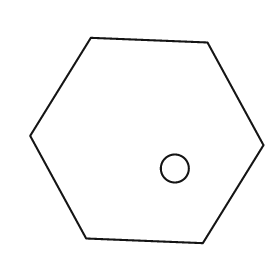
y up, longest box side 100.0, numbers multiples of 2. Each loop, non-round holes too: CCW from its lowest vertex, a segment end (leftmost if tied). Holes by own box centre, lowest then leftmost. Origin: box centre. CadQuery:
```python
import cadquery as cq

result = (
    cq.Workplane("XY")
    .moveTo(24.0, -44.0)
    .lineTo(50.0, -2.0)
    .lineTo(26.0, 42.0)
    .lineTo(-24.0, 44.0)
    .lineTo(-50.0, 2.0)
    .lineTo(-26.0, -42.0)
    .close()
    .moveTo(12.0, -12.0)
    .circle(6.0)
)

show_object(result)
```